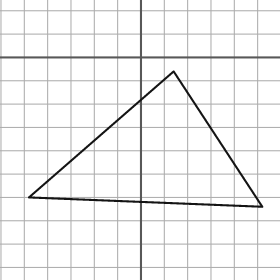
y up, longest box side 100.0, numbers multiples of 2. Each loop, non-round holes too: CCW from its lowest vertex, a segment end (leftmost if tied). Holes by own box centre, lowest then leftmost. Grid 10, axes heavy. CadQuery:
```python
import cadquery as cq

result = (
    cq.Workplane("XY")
    .moveTo(52.0, -64.0)
    .lineTo(14.0, -6.0)
    .lineTo(-48.0, -60.0)
    .close()
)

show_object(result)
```